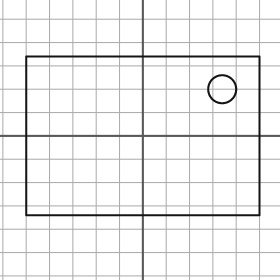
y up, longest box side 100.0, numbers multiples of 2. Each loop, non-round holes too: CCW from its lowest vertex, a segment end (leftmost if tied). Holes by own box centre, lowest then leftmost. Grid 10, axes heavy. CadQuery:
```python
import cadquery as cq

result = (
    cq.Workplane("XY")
    .moveTo(-50.0, -34.0)
    .lineTo(50.0, -34.0)
    .lineTo(50.0, 34.0)
    .lineTo(-50.0, 34.0)
    .close()
    .moveTo(34.0, 20.0)
    .circle(6.0)
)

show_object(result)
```